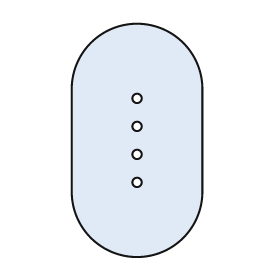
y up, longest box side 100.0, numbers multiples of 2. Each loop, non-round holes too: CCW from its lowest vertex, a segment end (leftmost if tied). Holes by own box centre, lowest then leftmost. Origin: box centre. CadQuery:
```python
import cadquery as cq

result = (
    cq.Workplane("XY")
    .moveTo(-28.0, -22.0)
    .threePointArc((0.0, -50.0), (28.0, -22.0))
    .lineTo(28.0, 22.0)
    .threePointArc((0.0, 50.0), (-28.0, 22.0))
    .close()
    .moveTo(0.0, -18.0)
    .circle(2.0)
    .moveTo(0.0, -6.0)
    .circle(2.0)
    .moveTo(0.0, 6.0)
    .circle(2.0)
    .moveTo(0.0, 18.0)
    .circle(2.0)
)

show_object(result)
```